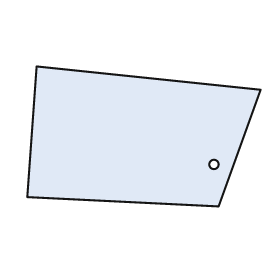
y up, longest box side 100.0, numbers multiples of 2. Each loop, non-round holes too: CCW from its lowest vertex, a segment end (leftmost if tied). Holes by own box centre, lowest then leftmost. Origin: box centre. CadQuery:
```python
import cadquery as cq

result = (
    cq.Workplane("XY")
    .moveTo(32.0, -30.0)
    .lineTo(50.0, 20.0)
    .lineTo(-46.0, 30.0)
    .lineTo(-50.0, -26.0)
    .close()
    .moveTo(30.0, -12.0)
    .circle(2.0)
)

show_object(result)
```